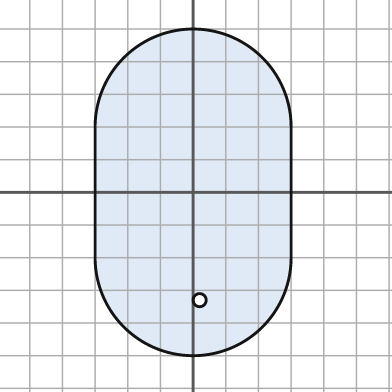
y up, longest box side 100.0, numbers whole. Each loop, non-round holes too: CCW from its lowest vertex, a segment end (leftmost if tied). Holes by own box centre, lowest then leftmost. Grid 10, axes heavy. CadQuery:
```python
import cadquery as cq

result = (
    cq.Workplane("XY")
    .moveTo(-30.0, -20.0)
    .threePointArc((0.0, -50.0), (30.0, -20.0))
    .lineTo(30.0, 20.0)
    .threePointArc((0.0, 50.0), (-30.0, 20.0))
    .close()
    .moveTo(2.0, -33.0)
    .circle(2.0)
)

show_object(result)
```